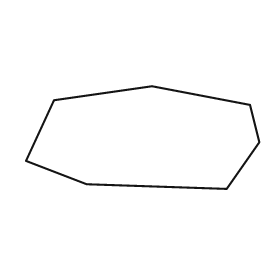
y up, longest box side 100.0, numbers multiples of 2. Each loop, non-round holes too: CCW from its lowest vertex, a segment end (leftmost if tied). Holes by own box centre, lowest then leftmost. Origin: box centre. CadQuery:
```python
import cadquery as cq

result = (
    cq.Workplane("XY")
    .moveTo(36.0, -22.0)
    .lineTo(50.0, -2.0)
    .lineTo(46.0, 14.0)
    .lineTo(4.0, 22.0)
    .lineTo(-38.0, 16.0)
    .lineTo(-50.0, -10.0)
    .lineTo(-24.0, -20.0)
    .close()
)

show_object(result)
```